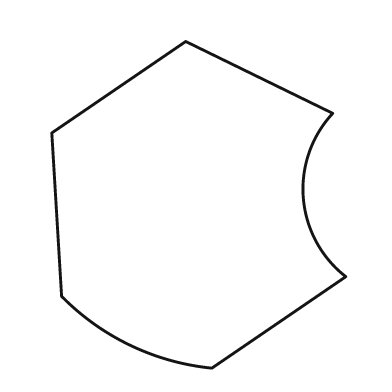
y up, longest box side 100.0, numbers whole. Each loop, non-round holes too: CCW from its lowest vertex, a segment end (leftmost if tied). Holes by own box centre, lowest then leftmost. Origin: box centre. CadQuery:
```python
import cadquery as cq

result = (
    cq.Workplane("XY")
    .moveTo(4.0, -50.0)
    .lineTo(45.0, -22.0)
    .threePointArc((32.0, 2.0), (41.0, 28.0))
    .lineTo(-4.0, 50.0)
    .lineTo(-45.0, 22.0)
    .lineTo(-42.0, -28.0)
    .threePointArc((-21.0, -43.0), (4.0, -50.0))
    .close()
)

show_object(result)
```